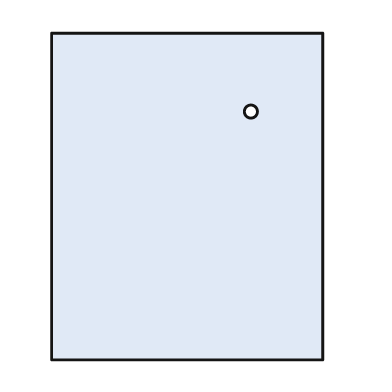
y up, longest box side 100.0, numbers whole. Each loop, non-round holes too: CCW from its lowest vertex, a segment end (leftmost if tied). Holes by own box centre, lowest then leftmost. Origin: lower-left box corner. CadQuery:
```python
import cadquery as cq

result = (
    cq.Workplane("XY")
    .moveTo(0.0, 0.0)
    .lineTo(83.0, 0.0)
    .lineTo(83.0, 100.0)
    .lineTo(0.0, 100.0)
    .close()
    .moveTo(61.0, 76.0)
    .circle(2.0)
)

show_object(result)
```